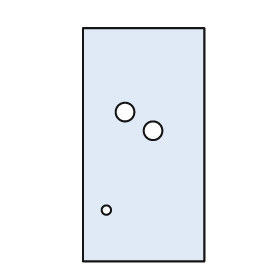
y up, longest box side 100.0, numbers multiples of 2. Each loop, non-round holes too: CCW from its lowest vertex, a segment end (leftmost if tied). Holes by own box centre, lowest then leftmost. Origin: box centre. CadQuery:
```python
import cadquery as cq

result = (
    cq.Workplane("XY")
    .moveTo(-26.0, -50.0)
    .lineTo(26.0, -50.0)
    .lineTo(26.0, 50.0)
    .lineTo(-26.0, 50.0)
    .close()
    .moveTo(-16.0, -28.0)
    .circle(2.0)
    .moveTo(4.0, 6.0)
    .circle(4.0)
    .moveTo(-8.0, 14.0)
    .circle(4.0)
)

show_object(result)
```